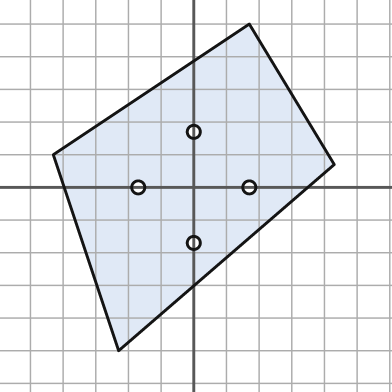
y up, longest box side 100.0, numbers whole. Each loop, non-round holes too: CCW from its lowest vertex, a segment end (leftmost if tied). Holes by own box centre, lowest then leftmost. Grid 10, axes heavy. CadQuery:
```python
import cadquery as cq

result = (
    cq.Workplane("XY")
    .moveTo(-23.0, -50.0)
    .lineTo(43.0, 7.0)
    .lineTo(17.0, 50.0)
    .lineTo(-43.0, 10.0)
    .close()
    .moveTo(0.0, -17.0)
    .circle(2.0)
    .moveTo(-17.0, 0.0)
    .circle(2.0)
    .moveTo(17.0, 0.0)
    .circle(2.0)
    .moveTo(0.0, 17.0)
    .circle(2.0)
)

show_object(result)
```